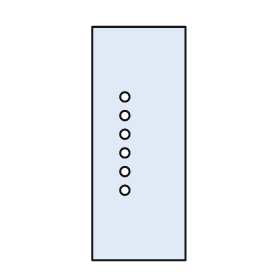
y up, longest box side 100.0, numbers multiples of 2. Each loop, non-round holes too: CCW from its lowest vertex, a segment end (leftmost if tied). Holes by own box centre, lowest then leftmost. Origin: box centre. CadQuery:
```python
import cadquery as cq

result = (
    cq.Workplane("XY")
    .moveTo(-20.0, -50.0)
    .lineTo(20.0, -50.0)
    .lineTo(20.0, 50.0)
    .lineTo(-20.0, 50.0)
    .close()
    .moveTo(-6.0, -20.0)
    .circle(2.0)
    .moveTo(-6.0, -12.0)
    .circle(2.0)
    .moveTo(-6.0, -4.0)
    .circle(2.0)
    .moveTo(-6.0, 4.0)
    .circle(2.0)
    .moveTo(-6.0, 12.0)
    .circle(2.0)
    .moveTo(-6.0, 20.0)
    .circle(2.0)
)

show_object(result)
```